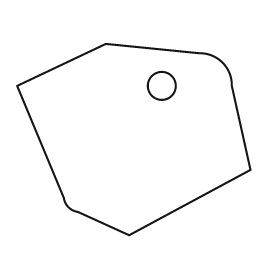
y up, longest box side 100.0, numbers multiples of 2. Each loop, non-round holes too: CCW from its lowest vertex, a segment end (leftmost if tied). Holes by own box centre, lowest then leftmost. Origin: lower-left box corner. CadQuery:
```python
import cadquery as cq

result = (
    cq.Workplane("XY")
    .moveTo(48.0, 0.0)
    .lineTo(100.0, 28.0)
    .lineTo(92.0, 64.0)
    .threePointArc((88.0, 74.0), (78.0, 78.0))
    .lineTo(38.0, 82.0)
    .lineTo(0.0, 64.0)
    .lineTo(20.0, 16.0)
    .threePointArc((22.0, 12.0), (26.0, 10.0))
    .close()
    .moveTo(62.0, 64.0)
    .circle(6.0)
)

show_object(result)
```